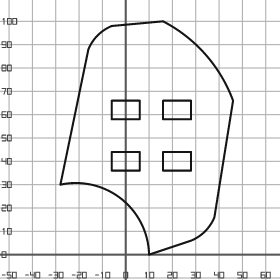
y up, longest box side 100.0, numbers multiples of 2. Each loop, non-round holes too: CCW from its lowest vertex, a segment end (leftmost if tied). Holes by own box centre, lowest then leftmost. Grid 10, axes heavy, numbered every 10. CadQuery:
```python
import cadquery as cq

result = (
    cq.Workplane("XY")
    .moveTo(10.0, 0.0)
    .lineTo(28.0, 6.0)
    .threePointArc((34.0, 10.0), (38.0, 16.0))
    .lineTo(46.0, 66.0)
    .threePointArc((34.0, 86.0), (16.0, 100.0))
    .lineTo(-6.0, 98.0)
    .threePointArc((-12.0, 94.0), (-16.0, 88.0))
    .lineTo(-28.0, 30.0)
    .threePointArc((-2.0, 24.0), (10.0, 0.0))
    .close()
    .moveTo(-6.0, 36.0)
    .lineTo(6.0, 36.0)
    .lineTo(6.0, 44.0)
    .lineTo(-6.0, 44.0)
    .close()
    .moveTo(16.0, 36.0)
    .lineTo(28.0, 36.0)
    .lineTo(28.0, 44.0)
    .lineTo(16.0, 44.0)
    .close()
    .moveTo(-6.0, 58.0)
    .lineTo(6.0, 58.0)
    .lineTo(6.0, 66.0)
    .lineTo(-6.0, 66.0)
    .close()
    .moveTo(16.0, 58.0)
    .lineTo(28.0, 58.0)
    .lineTo(28.0, 66.0)
    .lineTo(16.0, 66.0)
    .close()
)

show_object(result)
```